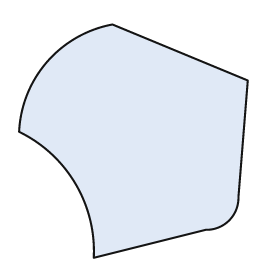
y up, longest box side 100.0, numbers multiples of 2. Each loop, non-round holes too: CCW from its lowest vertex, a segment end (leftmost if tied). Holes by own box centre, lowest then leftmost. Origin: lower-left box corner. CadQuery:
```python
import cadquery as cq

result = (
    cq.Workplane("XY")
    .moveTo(32.0, 0.0)
    .lineTo(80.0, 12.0)
    .threePointArc((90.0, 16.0), (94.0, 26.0))
    .lineTo(98.0, 76.0)
    .lineTo(40.0, 100.0)
    .threePointArc((12.0, 84.0), (0.0, 54.0))
    .threePointArc((24.0, 32.0), (32.0, 0.0))
    .close()
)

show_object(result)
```